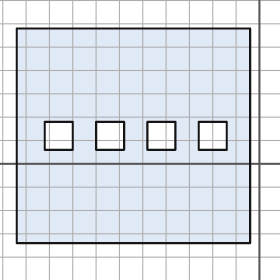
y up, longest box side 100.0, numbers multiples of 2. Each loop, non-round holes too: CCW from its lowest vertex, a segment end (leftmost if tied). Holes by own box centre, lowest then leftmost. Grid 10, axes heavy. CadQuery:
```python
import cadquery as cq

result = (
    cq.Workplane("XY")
    .moveTo(-104.0, -34.0)
    .lineTo(-4.0, -34.0)
    .lineTo(-4.0, 58.0)
    .lineTo(-104.0, 58.0)
    .close()
    .moveTo(-92.0, 6.0)
    .lineTo(-80.0, 6.0)
    .lineTo(-80.0, 18.0)
    .lineTo(-92.0, 18.0)
    .close()
    .moveTo(-70.0, 6.0)
    .lineTo(-58.0, 6.0)
    .lineTo(-58.0, 18.0)
    .lineTo(-70.0, 18.0)
    .close()
    .moveTo(-48.0, 6.0)
    .lineTo(-36.0, 6.0)
    .lineTo(-36.0, 18.0)
    .lineTo(-48.0, 18.0)
    .close()
    .moveTo(-26.0, 6.0)
    .lineTo(-14.0, 6.0)
    .lineTo(-14.0, 18.0)
    .lineTo(-26.0, 18.0)
    .close()
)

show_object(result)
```